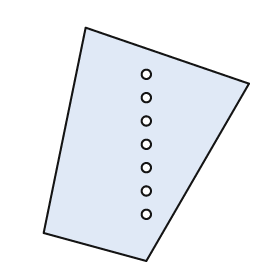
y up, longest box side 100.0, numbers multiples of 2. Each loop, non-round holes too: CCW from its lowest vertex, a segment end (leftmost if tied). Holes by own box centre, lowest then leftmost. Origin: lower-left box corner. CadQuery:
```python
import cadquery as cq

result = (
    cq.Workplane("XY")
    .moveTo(44.0, 0.0)
    .lineTo(88.0, 76.0)
    .lineTo(18.0, 100.0)
    .lineTo(0.0, 12.0)
    .close()
    .moveTo(44.0, 20.0)
    .circle(2.0)
    .moveTo(44.0, 30.0)
    .circle(2.0)
    .moveTo(44.0, 40.0)
    .circle(2.0)
    .moveTo(44.0, 50.0)
    .circle(2.0)
    .moveTo(44.0, 60.0)
    .circle(2.0)
    .moveTo(44.0, 70.0)
    .circle(2.0)
    .moveTo(44.0, 80.0)
    .circle(2.0)
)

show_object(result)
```